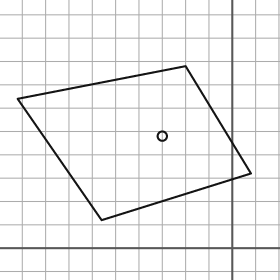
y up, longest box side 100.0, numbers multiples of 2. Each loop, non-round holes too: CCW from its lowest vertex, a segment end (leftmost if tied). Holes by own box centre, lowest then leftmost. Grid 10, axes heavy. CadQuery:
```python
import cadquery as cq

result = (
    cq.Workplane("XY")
    .moveTo(-56.0, 12.0)
    .lineTo(8.0, 32.0)
    .lineTo(-20.0, 78.0)
    .lineTo(-92.0, 64.0)
    .close()
    .moveTo(-30.0, 48.0)
    .circle(2.0)
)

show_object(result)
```